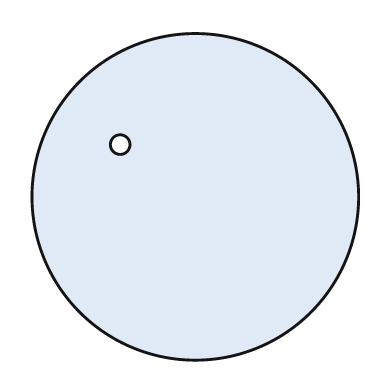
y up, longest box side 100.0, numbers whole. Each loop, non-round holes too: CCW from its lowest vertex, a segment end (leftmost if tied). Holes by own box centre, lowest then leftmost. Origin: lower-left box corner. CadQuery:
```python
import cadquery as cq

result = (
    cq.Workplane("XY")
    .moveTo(50.0, 50.0)
    .circle(50.0)
    .moveTo(27.0, 66.0)
    .circle(3.0)
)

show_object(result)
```